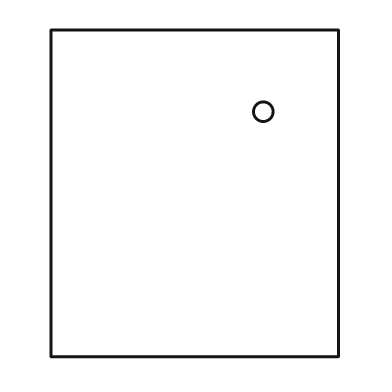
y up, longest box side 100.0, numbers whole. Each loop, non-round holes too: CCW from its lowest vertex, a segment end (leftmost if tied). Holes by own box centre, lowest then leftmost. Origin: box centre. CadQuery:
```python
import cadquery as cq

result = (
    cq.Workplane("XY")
    .moveTo(-44.0, -50.0)
    .lineTo(44.0, -50.0)
    .lineTo(44.0, 50.0)
    .lineTo(-44.0, 50.0)
    .close()
    .moveTo(21.0, 25.0)
    .circle(3.0)
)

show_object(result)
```